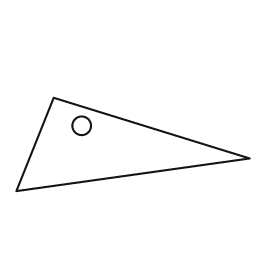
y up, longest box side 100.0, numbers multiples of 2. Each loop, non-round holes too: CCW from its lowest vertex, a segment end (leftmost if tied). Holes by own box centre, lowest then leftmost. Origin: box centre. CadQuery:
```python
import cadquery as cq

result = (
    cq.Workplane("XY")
    .moveTo(-50.0, -20.0)
    .lineTo(50.0, -6.0)
    .lineTo(-34.0, 20.0)
    .close()
    .moveTo(-22.0, 8.0)
    .circle(4.0)
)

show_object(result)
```